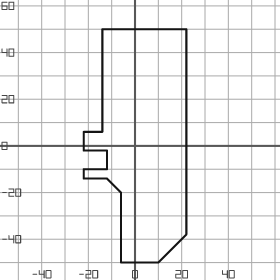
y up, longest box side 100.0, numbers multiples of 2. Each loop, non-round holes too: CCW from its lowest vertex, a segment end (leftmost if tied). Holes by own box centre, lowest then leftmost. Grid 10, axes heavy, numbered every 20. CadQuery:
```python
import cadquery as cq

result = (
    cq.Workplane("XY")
    .moveTo(-6.0, -50.0)
    .lineTo(10.0, -50.0)
    .lineTo(22.0, -38.0)
    .lineTo(22.0, 50.0)
    .lineTo(-14.0, 50.0)
    .lineTo(-14.0, 6.0)
    .lineTo(-22.0, 6.0)
    .lineTo(-22.0, -2.0)
    .lineTo(-12.0, -2.0)
    .lineTo(-12.0, -10.0)
    .lineTo(-22.0, -10.0)
    .lineTo(-22.0, -14.0)
    .lineTo(-12.0, -14.0)
    .lineTo(-6.0, -20.0)
    .close()
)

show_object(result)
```